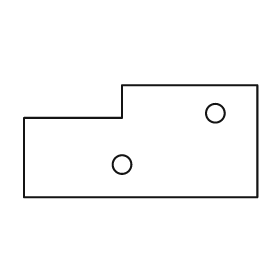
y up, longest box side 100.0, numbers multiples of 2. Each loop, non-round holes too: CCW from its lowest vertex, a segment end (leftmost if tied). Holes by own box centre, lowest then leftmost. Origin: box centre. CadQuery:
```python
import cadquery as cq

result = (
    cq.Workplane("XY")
    .moveTo(-50.0, -24.0)
    .lineTo(50.0, -24.0)
    .lineTo(50.0, 24.0)
    .lineTo(-8.0, 24.0)
    .lineTo(-8.0, 10.0)
    .lineTo(-50.0, 10.0)
    .close()
    .moveTo(-8.0, -10.0)
    .circle(4.0)
    .moveTo(32.0, 12.0)
    .circle(4.0)
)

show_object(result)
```